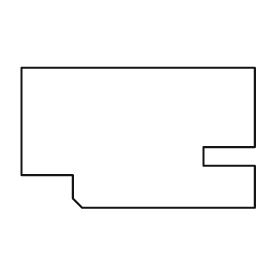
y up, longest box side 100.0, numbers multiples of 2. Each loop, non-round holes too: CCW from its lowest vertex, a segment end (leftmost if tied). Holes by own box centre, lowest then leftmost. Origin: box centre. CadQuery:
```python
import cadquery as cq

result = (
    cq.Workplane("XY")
    .moveTo(-24.0, -30.0)
    .lineTo(50.0, -30.0)
    .lineTo(50.0, -12.0)
    .lineTo(28.0, -12.0)
    .lineTo(28.0, -4.0)
    .lineTo(50.0, -4.0)
    .lineTo(50.0, 30.0)
    .lineTo(-50.0, 30.0)
    .lineTo(-50.0, -16.0)
    .lineTo(-28.0, -16.0)
    .lineTo(-28.0, -26.0)
    .close()
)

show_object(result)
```